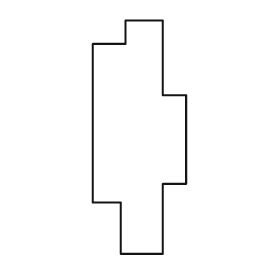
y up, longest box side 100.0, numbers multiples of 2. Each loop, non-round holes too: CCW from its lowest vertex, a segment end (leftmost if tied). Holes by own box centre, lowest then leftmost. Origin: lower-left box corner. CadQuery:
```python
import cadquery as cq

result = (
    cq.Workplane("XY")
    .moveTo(12.0, 0.0)
    .lineTo(30.0, 0.0)
    .lineTo(30.0, 30.0)
    .lineTo(40.0, 30.0)
    .lineTo(40.0, 68.0)
    .lineTo(30.0, 68.0)
    .lineTo(30.0, 100.0)
    .lineTo(14.0, 100.0)
    .lineTo(14.0, 90.0)
    .lineTo(0.0, 90.0)
    .lineTo(0.0, 22.0)
    .lineTo(12.0, 22.0)
    .close()
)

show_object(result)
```